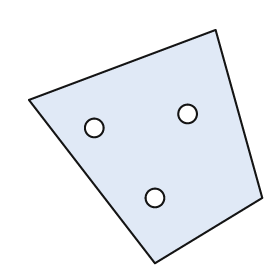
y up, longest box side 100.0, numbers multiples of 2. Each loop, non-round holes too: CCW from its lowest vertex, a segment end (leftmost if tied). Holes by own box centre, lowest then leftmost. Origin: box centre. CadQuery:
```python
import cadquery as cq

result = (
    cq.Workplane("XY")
    .moveTo(4.0, -50.0)
    .lineTo(50.0, -22.0)
    .lineTo(30.0, 50.0)
    .lineTo(-50.0, 20.0)
    .close()
    .moveTo(4.0, -22.0)
    .circle(4.0)
    .moveTo(-22.0, 8.0)
    .circle(4.0)
    .moveTo(18.0, 14.0)
    .circle(4.0)
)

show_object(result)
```